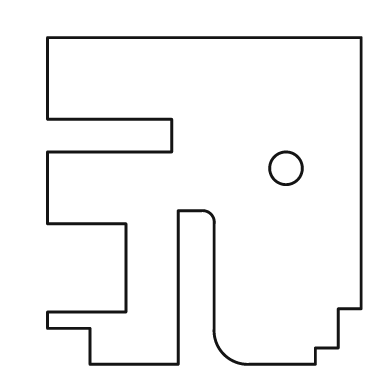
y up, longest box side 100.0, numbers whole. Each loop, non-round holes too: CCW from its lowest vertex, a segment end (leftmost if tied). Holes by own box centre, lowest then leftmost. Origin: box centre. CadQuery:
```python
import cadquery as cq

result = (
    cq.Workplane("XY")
    .moveTo(-35.0, -50.0)
    .lineTo(-8.0, -50.0)
    .lineTo(-8.0, -3.0)
    .lineTo(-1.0, -3.0)
    .threePointArc((2.0, -4.0), (3.0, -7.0))
    .lineTo(3.0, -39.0)
    .threePointArc((6.0, -47.0), (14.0, -50.0))
    .lineTo(34.0, -50.0)
    .lineTo(34.0, -45.0)
    .lineTo(41.0, -45.0)
    .lineTo(41.0, -33.0)
    .lineTo(48.0, -33.0)
    .lineTo(48.0, 50.0)
    .lineTo(-48.0, 50.0)
    .lineTo(-48.0, 25.0)
    .lineTo(-10.0, 25.0)
    .lineTo(-10.0, 15.0)
    .lineTo(-48.0, 15.0)
    .lineTo(-48.0, -7.0)
    .lineTo(-24.0, -7.0)
    .lineTo(-24.0, -34.0)
    .lineTo(-48.0, -34.0)
    .lineTo(-48.0, -39.0)
    .lineTo(-35.0, -39.0)
    .close()
    .moveTo(25.0, 10.0)
    .circle(5.0)
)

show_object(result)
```